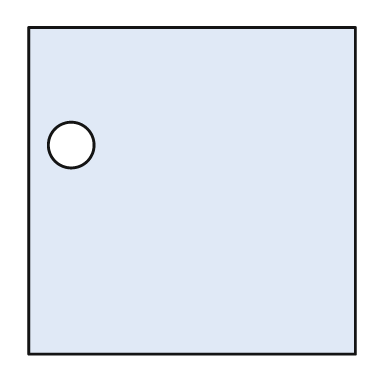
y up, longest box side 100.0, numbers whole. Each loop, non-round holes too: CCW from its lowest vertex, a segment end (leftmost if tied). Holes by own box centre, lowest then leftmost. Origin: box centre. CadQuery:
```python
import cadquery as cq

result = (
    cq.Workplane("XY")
    .moveTo(-50.0, -50.0)
    .lineTo(50.0, -50.0)
    .lineTo(50.0, 50.0)
    .lineTo(-50.0, 50.0)
    .close()
    .moveTo(-37.0, 14.0)
    .circle(7.0)
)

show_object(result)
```